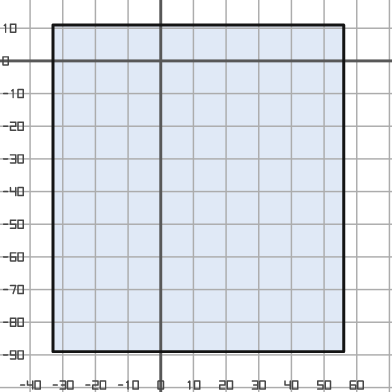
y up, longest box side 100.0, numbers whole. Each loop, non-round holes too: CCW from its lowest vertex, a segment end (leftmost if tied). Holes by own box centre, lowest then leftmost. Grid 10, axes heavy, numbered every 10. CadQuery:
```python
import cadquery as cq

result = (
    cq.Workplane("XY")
    .moveTo(-33.0, -89.0)
    .lineTo(56.0, -89.0)
    .lineTo(56.0, 11.0)
    .lineTo(-33.0, 11.0)
    .close()
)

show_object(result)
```